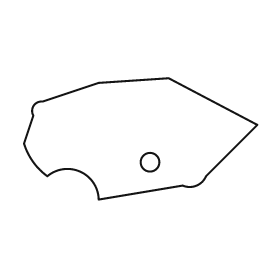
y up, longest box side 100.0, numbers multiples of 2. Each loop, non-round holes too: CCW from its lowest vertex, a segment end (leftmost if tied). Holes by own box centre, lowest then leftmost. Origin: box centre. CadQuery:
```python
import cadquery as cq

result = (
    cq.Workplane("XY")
    .moveTo(-18.0, -26.0)
    .lineTo(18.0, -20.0)
    .threePointArc((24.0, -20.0), (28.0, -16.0))
    .lineTo(50.0, 6.0)
    .lineTo(12.0, 26.0)
    .lineTo(-18.0, 24.0)
    .lineTo(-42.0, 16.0)
    .threePointArc((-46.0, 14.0), (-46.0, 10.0))
    .lineTo(-50.0, -2.0)
    .threePointArc((-46.0, -10.0), (-40.0, -16.0))
    .threePointArc((-26.0, -14.0), (-18.0, -26.0))
    .close()
    .moveTo(4.0, -10.0)
    .circle(4.0)
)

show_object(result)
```